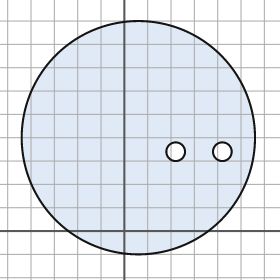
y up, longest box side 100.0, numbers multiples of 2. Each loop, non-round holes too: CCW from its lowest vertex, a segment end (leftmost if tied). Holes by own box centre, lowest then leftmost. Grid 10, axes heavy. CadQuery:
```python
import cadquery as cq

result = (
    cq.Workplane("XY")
    .moveTo(6.0, 40.0)
    .circle(50.0)
    .moveTo(22.0, 34.0)
    .circle(4.0)
    .moveTo(42.0, 34.0)
    .circle(4.0)
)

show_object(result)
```